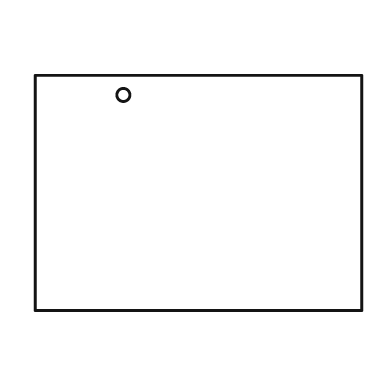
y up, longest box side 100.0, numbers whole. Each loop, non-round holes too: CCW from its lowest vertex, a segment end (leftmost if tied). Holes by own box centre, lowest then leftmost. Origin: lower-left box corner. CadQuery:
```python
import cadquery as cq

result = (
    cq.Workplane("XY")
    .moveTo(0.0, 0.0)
    .lineTo(100.0, 0.0)
    .lineTo(100.0, 72.0)
    .lineTo(0.0, 72.0)
    .close()
    .moveTo(27.0, 66.0)
    .circle(2.0)
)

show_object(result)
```